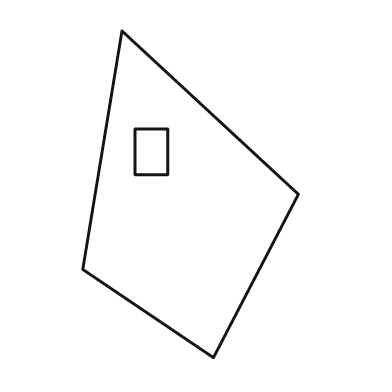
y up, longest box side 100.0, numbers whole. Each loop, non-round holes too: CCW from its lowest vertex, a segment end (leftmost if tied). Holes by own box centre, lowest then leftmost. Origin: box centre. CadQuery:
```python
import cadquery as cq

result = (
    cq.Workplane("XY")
    .moveTo(7.0, -50.0)
    .lineTo(33.0, 0.0)
    .lineTo(-21.0, 50.0)
    .lineTo(-33.0, -23.0)
    .close()
    .moveTo(-17.0, 6.0)
    .lineTo(-7.0, 6.0)
    .lineTo(-7.0, 20.0)
    .lineTo(-17.0, 20.0)
    .close()
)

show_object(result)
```